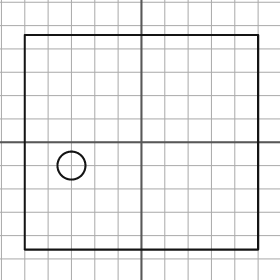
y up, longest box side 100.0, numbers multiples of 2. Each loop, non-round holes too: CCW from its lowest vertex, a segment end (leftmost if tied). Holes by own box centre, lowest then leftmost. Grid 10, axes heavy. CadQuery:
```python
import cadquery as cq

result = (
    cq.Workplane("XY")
    .moveTo(-50.0, -46.0)
    .lineTo(50.0, -46.0)
    .lineTo(50.0, 46.0)
    .lineTo(-50.0, 46.0)
    .close()
    .moveTo(-30.0, -10.0)
    .circle(6.0)
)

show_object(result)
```